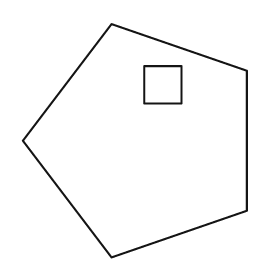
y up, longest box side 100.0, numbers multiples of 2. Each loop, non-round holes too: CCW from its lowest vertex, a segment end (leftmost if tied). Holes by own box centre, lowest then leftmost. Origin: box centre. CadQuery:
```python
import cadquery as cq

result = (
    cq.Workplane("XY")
    .moveTo(-10.0, -50.0)
    .lineTo(48.0, -30.0)
    .lineTo(48.0, 30.0)
    .lineTo(-10.0, 50.0)
    .lineTo(-48.0, 0.0)
    .close()
    .moveTo(4.0, 16.0)
    .lineTo(20.0, 16.0)
    .lineTo(20.0, 32.0)
    .lineTo(4.0, 32.0)
    .close()
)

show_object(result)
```